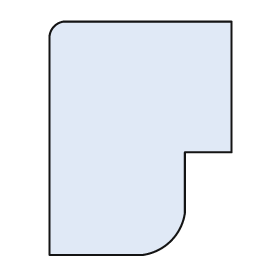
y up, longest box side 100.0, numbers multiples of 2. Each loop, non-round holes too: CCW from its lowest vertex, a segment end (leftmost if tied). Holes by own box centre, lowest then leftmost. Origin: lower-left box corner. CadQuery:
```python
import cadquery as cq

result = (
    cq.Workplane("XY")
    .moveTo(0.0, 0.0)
    .lineTo(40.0, 0.0)
    .threePointArc((52.0, 6.0), (58.0, 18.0))
    .lineTo(58.0, 44.0)
    .lineTo(78.0, 44.0)
    .lineTo(78.0, 100.0)
    .lineTo(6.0, 100.0)
    .threePointArc((2.0, 98.0), (0.0, 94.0))
    .close()
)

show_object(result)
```